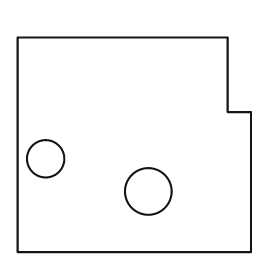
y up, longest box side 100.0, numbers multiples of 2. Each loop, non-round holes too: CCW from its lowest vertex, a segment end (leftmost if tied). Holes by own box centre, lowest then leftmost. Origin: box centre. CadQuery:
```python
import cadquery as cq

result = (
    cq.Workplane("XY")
    .moveTo(-50.0, -46.0)
    .lineTo(50.0, -46.0)
    .lineTo(50.0, 14.0)
    .lineTo(40.0, 14.0)
    .lineTo(40.0, 46.0)
    .lineTo(-50.0, 46.0)
    .close()
    .moveTo(6.0, -20.0)
    .circle(10.0)
    .moveTo(-38.0, -6.0)
    .circle(8.0)
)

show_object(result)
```